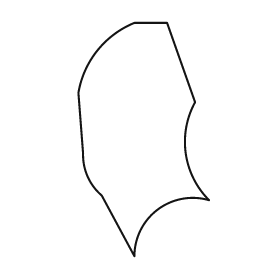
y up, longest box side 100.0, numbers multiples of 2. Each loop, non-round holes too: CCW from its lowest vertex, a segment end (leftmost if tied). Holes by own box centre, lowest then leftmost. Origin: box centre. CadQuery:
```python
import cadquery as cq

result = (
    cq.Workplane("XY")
    .moveTo(-4.0, -50.0)
    .threePointArc((6.0, -30.0), (28.0, -26.0))
    .threePointArc((18.0, -6.0), (22.0, 16.0))
    .lineTo(10.0, 50.0)
    .lineTo(-4.0, 50.0)
    .threePointArc((-20.0, 38.0), (-28.0, 20.0))
    .lineTo(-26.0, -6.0)
    .threePointArc((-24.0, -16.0), (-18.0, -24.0))
    .close()
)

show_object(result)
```